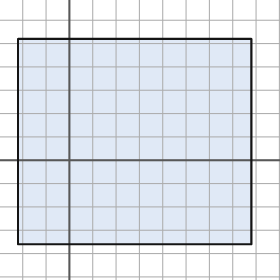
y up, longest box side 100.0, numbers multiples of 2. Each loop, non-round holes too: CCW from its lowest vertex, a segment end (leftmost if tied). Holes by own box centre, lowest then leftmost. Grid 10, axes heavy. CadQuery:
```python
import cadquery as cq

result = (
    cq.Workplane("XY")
    .moveTo(-22.0, -36.0)
    .lineTo(78.0, -36.0)
    .lineTo(78.0, 52.0)
    .lineTo(-22.0, 52.0)
    .close()
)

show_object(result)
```